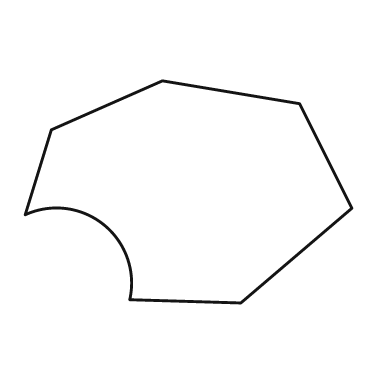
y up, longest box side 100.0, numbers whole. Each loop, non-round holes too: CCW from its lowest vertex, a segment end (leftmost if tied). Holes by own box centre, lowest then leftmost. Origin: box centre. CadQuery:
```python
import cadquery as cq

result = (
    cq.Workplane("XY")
    .moveTo(16.0, -34.0)
    .lineTo(50.0, -5.0)
    .lineTo(34.0, 27.0)
    .lineTo(-8.0, 34.0)
    .lineTo(-42.0, 19.0)
    .lineTo(-50.0, -7.0)
    .threePointArc((-26.0, -10.0), (-18.0, -33.0))
    .close()
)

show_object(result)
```